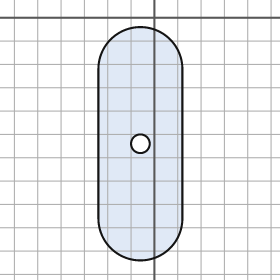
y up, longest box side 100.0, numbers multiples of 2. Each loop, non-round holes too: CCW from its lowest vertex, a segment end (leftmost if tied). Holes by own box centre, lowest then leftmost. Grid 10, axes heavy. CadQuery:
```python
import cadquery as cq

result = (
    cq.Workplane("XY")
    .moveTo(-24.0, -86.0)
    .threePointArc((-6.0, -104.0), (12.0, -86.0))
    .lineTo(12.0, -22.0)
    .threePointArc((-6.0, -4.0), (-24.0, -22.0))
    .close()
    .moveTo(-6.0, -54.0)
    .circle(4.0)
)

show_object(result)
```